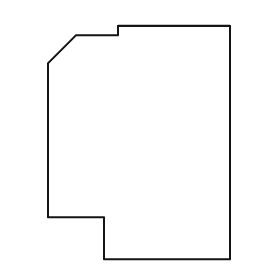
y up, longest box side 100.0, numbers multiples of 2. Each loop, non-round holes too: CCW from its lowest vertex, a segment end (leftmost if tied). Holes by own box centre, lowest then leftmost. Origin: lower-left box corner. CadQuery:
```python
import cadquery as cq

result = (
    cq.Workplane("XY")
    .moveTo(24.0, 0.0)
    .lineTo(78.0, 0.0)
    .lineTo(78.0, 100.0)
    .lineTo(30.0, 100.0)
    .lineTo(30.0, 96.0)
    .lineTo(12.0, 96.0)
    .lineTo(0.0, 84.0)
    .lineTo(0.0, 18.0)
    .lineTo(24.0, 18.0)
    .close()
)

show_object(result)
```